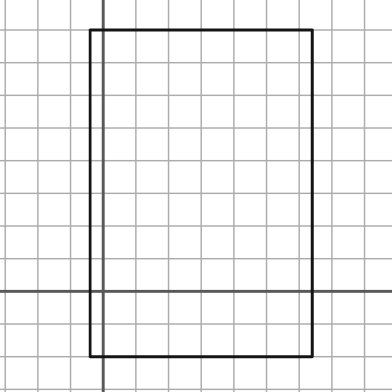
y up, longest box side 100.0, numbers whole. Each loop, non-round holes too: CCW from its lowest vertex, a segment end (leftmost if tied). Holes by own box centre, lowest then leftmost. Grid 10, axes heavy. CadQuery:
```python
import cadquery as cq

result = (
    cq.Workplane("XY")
    .moveTo(-4.0, -20.0)
    .lineTo(64.0, -20.0)
    .lineTo(64.0, 80.0)
    .lineTo(-4.0, 80.0)
    .close()
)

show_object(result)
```